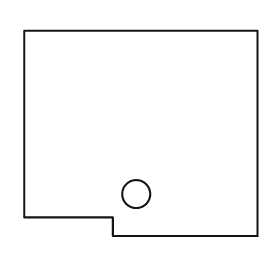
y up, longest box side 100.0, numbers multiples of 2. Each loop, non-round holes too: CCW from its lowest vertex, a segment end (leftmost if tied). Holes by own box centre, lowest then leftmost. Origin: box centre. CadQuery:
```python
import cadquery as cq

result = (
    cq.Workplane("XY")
    .moveTo(-12.0, -44.0)
    .lineTo(50.0, -44.0)
    .lineTo(50.0, 44.0)
    .lineTo(-50.0, 44.0)
    .lineTo(-50.0, -36.0)
    .lineTo(-12.0, -36.0)
    .close()
    .moveTo(-2.0, -26.0)
    .circle(6.0)
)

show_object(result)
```